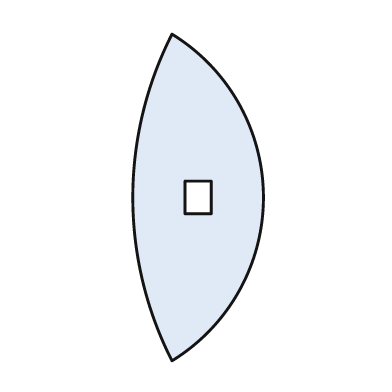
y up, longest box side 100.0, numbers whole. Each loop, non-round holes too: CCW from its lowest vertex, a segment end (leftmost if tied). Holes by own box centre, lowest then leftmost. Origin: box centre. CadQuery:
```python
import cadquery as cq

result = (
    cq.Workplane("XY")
    .moveTo(-8.0, -50.0)
    .threePointArc((20.0, 0.0), (-8.0, 50.0))
    .threePointArc((-20.0, 0.0), (-8.0, -50.0))
    .close()
    .moveTo(-4.0, -5.0)
    .lineTo(4.0, -5.0)
    .lineTo(4.0, 5.0)
    .lineTo(-4.0, 5.0)
    .close()
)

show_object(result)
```